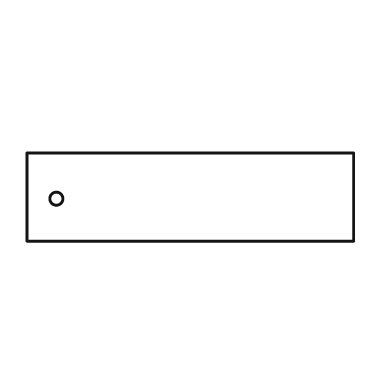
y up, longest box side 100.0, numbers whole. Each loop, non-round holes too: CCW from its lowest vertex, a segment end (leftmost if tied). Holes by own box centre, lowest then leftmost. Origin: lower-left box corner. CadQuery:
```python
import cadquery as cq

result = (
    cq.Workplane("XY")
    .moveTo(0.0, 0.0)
    .lineTo(100.0, 0.0)
    .lineTo(100.0, 27.0)
    .lineTo(0.0, 27.0)
    .close()
    .moveTo(9.0, 13.0)
    .circle(2.0)
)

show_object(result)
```